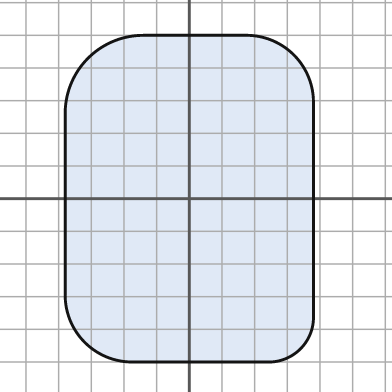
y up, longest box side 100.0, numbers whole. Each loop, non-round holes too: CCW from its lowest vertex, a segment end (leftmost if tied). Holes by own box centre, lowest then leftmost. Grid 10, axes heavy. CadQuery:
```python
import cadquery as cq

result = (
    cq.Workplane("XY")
    .moveTo(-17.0, -50.0)
    .lineTo(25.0, -50.0)
    .threePointArc((34.0, -46.0), (38.0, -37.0))
    .lineTo(38.0, 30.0)
    .threePointArc((32.0, 44.0), (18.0, 50.0))
    .lineTo(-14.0, 50.0)
    .threePointArc((-31.0, 43.0), (-38.0, 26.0))
    .lineTo(-38.0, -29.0)
    .threePointArc((-32.0, -44.0), (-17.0, -50.0))
    .close()
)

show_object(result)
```